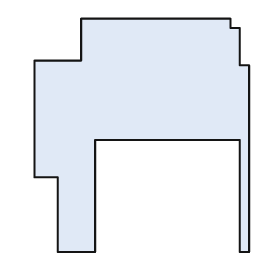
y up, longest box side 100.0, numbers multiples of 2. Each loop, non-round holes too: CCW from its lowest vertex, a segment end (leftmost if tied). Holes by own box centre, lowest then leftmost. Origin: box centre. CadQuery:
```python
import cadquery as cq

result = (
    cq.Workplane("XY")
    .moveTo(-36.0, -50.0)
    .lineTo(-20.0, -50.0)
    .lineTo(-20.0, -2.0)
    .lineTo(42.0, -2.0)
    .lineTo(42.0, -50.0)
    .lineTo(46.0, -50.0)
    .lineTo(46.0, 30.0)
    .lineTo(42.0, 30.0)
    .lineTo(42.0, 46.0)
    .lineTo(38.0, 46.0)
    .lineTo(38.0, 50.0)
    .lineTo(-26.0, 50.0)
    .lineTo(-26.0, 32.0)
    .lineTo(-46.0, 32.0)
    .lineTo(-46.0, -18.0)
    .lineTo(-36.0, -18.0)
    .close()
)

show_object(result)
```